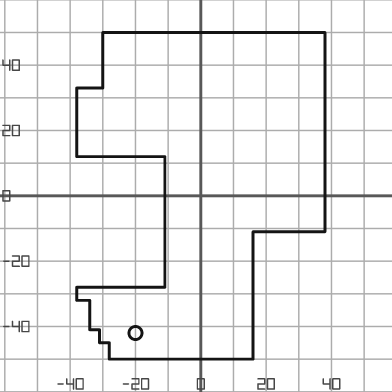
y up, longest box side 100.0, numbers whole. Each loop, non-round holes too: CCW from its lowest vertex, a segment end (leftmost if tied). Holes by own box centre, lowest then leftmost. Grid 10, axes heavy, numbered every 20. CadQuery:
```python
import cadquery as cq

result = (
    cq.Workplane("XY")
    .moveTo(-28.0, -50.0)
    .lineTo(16.0, -50.0)
    .lineTo(16.0, -11.0)
    .lineTo(38.0, -11.0)
    .lineTo(38.0, 50.0)
    .lineTo(-30.0, 50.0)
    .lineTo(-30.0, 33.0)
    .lineTo(-38.0, 33.0)
    .lineTo(-38.0, 12.0)
    .lineTo(-11.0, 12.0)
    .lineTo(-11.0, -28.0)
    .lineTo(-38.0, -28.0)
    .lineTo(-38.0, -32.0)
    .lineTo(-34.0, -32.0)
    .lineTo(-34.0, -41.0)
    .lineTo(-31.0, -41.0)
    .lineTo(-31.0, -45.0)
    .lineTo(-28.0, -45.0)
    .close()
    .moveTo(-20.0, -42.0)
    .circle(2.0)
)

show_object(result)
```